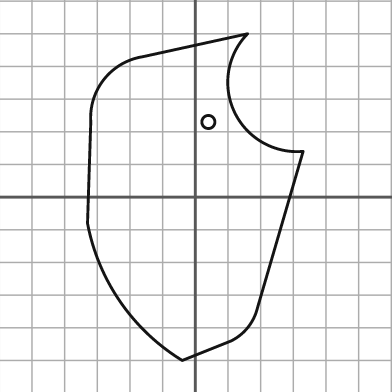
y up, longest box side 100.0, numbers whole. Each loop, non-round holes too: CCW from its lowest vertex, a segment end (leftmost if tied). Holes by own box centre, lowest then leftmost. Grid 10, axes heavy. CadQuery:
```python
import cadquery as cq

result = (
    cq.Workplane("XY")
    .moveTo(-4.0, -50.0)
    .lineTo(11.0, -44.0)
    .threePointArc((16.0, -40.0), (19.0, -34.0))
    .lineTo(33.0, 14.0)
    .threePointArc((12.0, 26.0), (16.0, 50.0))
    .lineTo(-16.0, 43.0)
    .threePointArc((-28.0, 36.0), (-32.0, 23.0))
    .lineTo(-33.0, -8.0)
    .threePointArc((-23.0, -32.0), (-4.0, -50.0))
    .close()
    .moveTo(4.0, 23.0)
    .circle(2.0)
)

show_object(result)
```